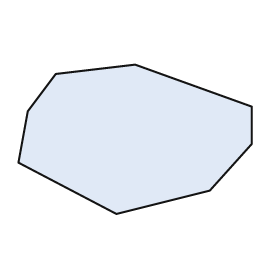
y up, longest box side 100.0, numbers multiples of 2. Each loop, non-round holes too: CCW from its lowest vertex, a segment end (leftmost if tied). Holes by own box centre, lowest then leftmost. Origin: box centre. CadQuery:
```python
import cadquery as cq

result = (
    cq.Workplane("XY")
    .moveTo(-8.0, -32.0)
    .lineTo(32.0, -22.0)
    .lineTo(50.0, -2.0)
    .lineTo(50.0, 14.0)
    .lineTo(0.0, 32.0)
    .lineTo(-34.0, 28.0)
    .lineTo(-46.0, 12.0)
    .lineTo(-50.0, -10.0)
    .close()
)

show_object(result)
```